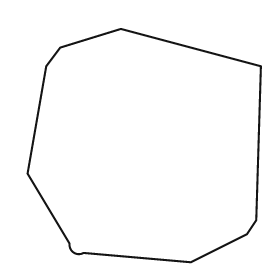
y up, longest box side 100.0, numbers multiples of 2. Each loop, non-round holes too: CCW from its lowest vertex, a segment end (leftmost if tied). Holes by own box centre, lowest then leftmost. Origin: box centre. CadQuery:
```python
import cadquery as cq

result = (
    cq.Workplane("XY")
    .moveTo(20.0, -50.0)
    .lineTo(44.0, -38.0)
    .lineTo(48.0, -32.0)
    .lineTo(50.0, 34.0)
    .lineTo(-10.0, 50.0)
    .lineTo(-36.0, 42.0)
    .lineTo(-42.0, 34.0)
    .lineTo(-50.0, -12.0)
    .lineTo(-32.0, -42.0)
    .threePointArc((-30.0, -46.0), (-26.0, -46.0))
    .close()
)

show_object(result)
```